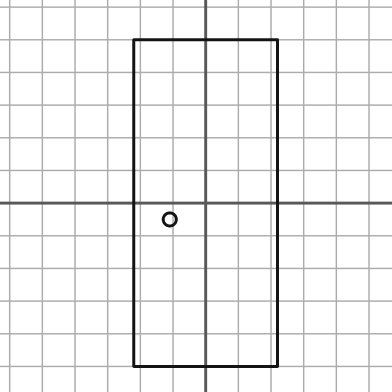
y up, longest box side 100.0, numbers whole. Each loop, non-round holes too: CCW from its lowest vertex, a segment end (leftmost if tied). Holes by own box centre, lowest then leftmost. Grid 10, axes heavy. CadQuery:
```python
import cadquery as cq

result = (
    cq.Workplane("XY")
    .moveTo(-22.0, -50.0)
    .lineTo(22.0, -50.0)
    .lineTo(22.0, 50.0)
    .lineTo(-22.0, 50.0)
    .close()
    .moveTo(-11.0, -5.0)
    .circle(2.0)
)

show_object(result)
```